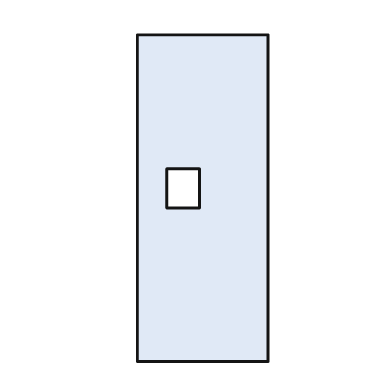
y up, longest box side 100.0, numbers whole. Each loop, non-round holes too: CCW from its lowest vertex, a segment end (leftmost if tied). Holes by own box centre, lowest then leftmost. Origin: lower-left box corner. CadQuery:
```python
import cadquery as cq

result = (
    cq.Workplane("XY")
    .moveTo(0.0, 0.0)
    .lineTo(40.0, 0.0)
    .lineTo(40.0, 100.0)
    .lineTo(0.0, 100.0)
    .close()
    .moveTo(9.0, 47.0)
    .lineTo(19.0, 47.0)
    .lineTo(19.0, 59.0)
    .lineTo(9.0, 59.0)
    .close()
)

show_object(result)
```